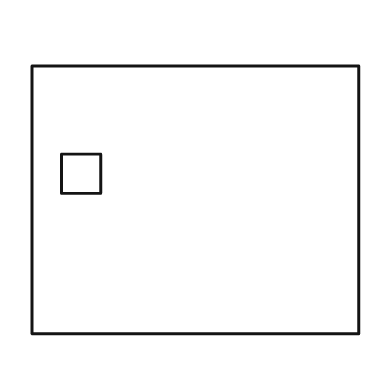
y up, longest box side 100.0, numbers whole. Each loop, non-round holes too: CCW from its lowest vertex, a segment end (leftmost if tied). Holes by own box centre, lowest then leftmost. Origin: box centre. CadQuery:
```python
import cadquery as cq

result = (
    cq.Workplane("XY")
    .moveTo(-50.0, -41.0)
    .lineTo(50.0, -41.0)
    .lineTo(50.0, 41.0)
    .lineTo(-50.0, 41.0)
    .close()
    .moveTo(-41.0, 2.0)
    .lineTo(-29.0, 2.0)
    .lineTo(-29.0, 14.0)
    .lineTo(-41.0, 14.0)
    .close()
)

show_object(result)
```